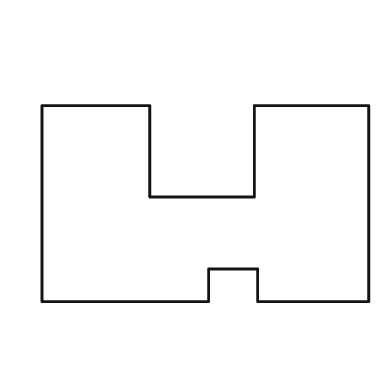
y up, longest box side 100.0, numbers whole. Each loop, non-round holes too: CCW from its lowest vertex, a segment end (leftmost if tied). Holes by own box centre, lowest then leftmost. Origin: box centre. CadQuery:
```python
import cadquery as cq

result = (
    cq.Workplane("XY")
    .moveTo(-50.0, -30.0)
    .lineTo(1.0, -30.0)
    .lineTo(1.0, -20.0)
    .lineTo(16.0, -20.0)
    .lineTo(16.0, -30.0)
    .lineTo(50.0, -30.0)
    .lineTo(50.0, 30.0)
    .lineTo(15.0, 30.0)
    .lineTo(15.0, 2.0)
    .lineTo(-17.0, 2.0)
    .lineTo(-17.0, 30.0)
    .lineTo(-50.0, 30.0)
    .close()
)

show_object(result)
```